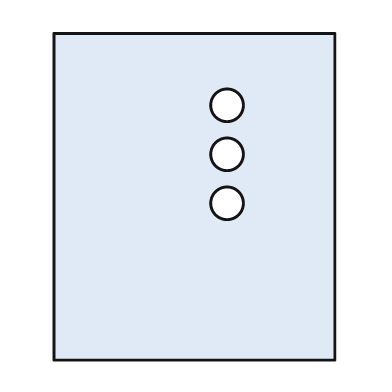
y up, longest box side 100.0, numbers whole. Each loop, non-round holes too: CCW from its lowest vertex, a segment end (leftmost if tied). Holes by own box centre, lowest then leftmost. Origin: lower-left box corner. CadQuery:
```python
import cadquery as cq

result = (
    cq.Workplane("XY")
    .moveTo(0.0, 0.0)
    .lineTo(86.0, 0.0)
    .lineTo(86.0, 100.0)
    .lineTo(0.0, 100.0)
    .close()
    .moveTo(53.0, 48.0)
    .circle(5.0)
    .moveTo(53.0, 63.0)
    .circle(5.0)
    .moveTo(53.0, 78.0)
    .circle(5.0)
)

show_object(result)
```